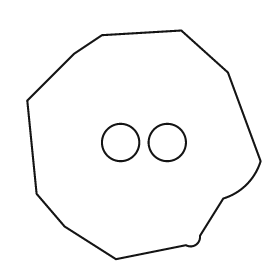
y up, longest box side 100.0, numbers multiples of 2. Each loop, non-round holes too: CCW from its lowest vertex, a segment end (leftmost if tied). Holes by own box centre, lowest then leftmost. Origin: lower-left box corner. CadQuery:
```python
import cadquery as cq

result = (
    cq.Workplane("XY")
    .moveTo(38.0, 0.0)
    .lineTo(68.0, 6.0)
    .threePointArc((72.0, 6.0), (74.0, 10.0))
    .lineTo(84.0, 26.0)
    .threePointArc((94.0, 32.0), (100.0, 42.0))
    .lineTo(86.0, 80.0)
    .lineTo(66.0, 98.0)
    .lineTo(32.0, 96.0)
    .lineTo(20.0, 88.0)
    .lineTo(0.0, 68.0)
    .lineTo(4.0, 28.0)
    .lineTo(16.0, 14.0)
    .close()
    .moveTo(40.0, 50.0)
    .circle(8.0)
    .moveTo(60.0, 50.0)
    .circle(8.0)
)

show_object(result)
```